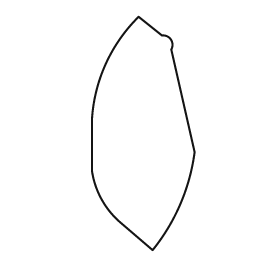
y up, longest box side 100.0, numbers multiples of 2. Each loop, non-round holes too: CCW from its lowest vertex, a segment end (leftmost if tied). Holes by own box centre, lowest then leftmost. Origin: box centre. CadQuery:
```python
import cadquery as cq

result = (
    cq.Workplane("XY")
    .moveTo(4.0, -50.0)
    .threePointArc((16.0, -30.0), (22.0, -8.0))
    .lineTo(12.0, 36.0)
    .threePointArc((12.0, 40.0), (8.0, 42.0))
    .lineTo(-2.0, 50.0)
    .threePointArc((-16.0, 30.0), (-22.0, 6.0))
    .lineTo(-22.0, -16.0)
    .threePointArc((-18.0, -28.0), (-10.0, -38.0))
    .close()
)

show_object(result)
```